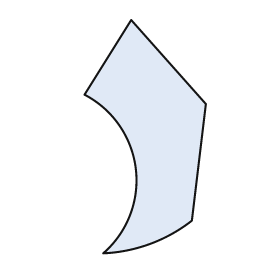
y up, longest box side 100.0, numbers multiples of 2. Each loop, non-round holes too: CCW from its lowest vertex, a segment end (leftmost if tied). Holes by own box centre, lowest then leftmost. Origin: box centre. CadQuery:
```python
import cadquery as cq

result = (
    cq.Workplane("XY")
    .moveTo(-18.0, -50.0)
    .threePointArc((2.0, -46.0), (20.0, -36.0))
    .lineTo(26.0, 14.0)
    .lineTo(-6.0, 50.0)
    .lineTo(-26.0, 18.0)
    .threePointArc((-4.0, -14.0), (-18.0, -50.0))
    .close()
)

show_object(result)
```